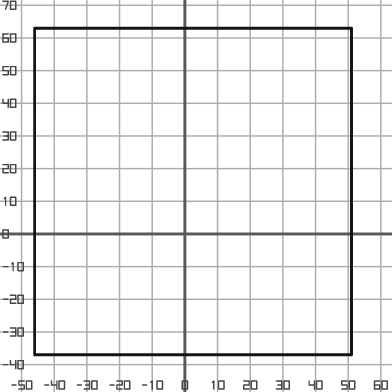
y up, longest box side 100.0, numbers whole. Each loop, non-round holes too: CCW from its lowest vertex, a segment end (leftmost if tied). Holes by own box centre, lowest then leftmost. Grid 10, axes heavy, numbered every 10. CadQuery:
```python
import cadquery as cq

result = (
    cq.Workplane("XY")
    .moveTo(-46.0, -37.0)
    .lineTo(51.0, -37.0)
    .lineTo(51.0, 63.0)
    .lineTo(-46.0, 63.0)
    .close()
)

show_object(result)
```